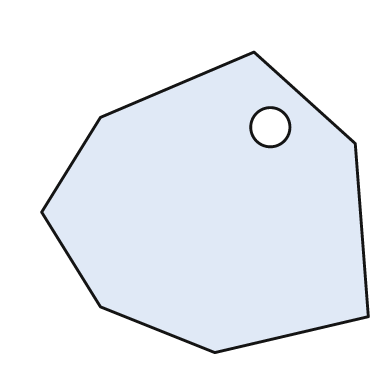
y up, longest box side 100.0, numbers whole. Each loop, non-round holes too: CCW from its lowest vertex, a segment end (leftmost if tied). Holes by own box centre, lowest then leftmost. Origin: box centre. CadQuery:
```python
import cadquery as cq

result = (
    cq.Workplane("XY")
    .moveTo(3.0, -46.0)
    .lineTo(50.0, -35.0)
    .lineTo(46.0, 18.0)
    .lineTo(15.0, 46.0)
    .lineTo(-32.0, 26.0)
    .lineTo(-50.0, -3.0)
    .lineTo(-32.0, -32.0)
    .close()
    .moveTo(20.0, 23.0)
    .circle(6.0)
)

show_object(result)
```